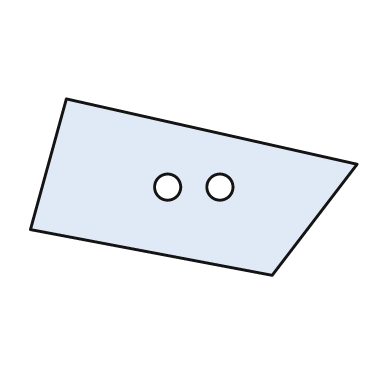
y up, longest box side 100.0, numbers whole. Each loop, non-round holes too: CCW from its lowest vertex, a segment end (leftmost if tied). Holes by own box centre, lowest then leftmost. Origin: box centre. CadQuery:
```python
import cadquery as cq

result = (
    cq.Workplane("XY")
    .moveTo(24.0, -27.0)
    .lineTo(50.0, 7.0)
    .lineTo(-39.0, 27.0)
    .lineTo(-50.0, -13.0)
    .close()
    .moveTo(-8.0, 0.0)
    .circle(4.0)
    .moveTo(8.0, 0.0)
    .circle(4.0)
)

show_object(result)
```